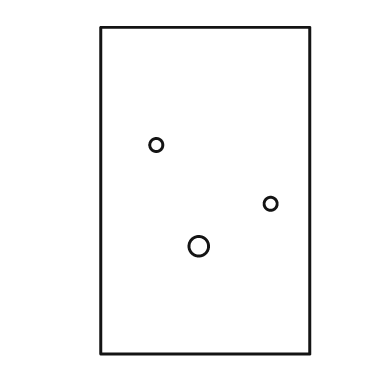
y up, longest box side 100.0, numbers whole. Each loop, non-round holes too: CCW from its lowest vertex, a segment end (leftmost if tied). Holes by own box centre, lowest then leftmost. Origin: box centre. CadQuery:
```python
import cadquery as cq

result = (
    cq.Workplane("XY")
    .moveTo(-32.0, -50.0)
    .lineTo(32.0, -50.0)
    .lineTo(32.0, 50.0)
    .lineTo(-32.0, 50.0)
    .close()
    .moveTo(-2.0, -17.0)
    .circle(3.0)
    .moveTo(20.0, -4.0)
    .circle(2.0)
    .moveTo(-15.0, 14.0)
    .circle(2.0)
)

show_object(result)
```